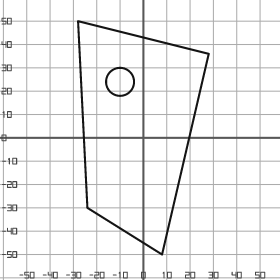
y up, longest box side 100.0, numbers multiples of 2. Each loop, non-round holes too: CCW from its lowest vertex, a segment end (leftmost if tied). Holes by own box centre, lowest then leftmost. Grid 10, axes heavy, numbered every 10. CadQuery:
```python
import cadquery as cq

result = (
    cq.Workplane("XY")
    .moveTo(8.0, -50.0)
    .lineTo(28.0, 36.0)
    .lineTo(-28.0, 50.0)
    .lineTo(-24.0, -30.0)
    .close()
    .moveTo(-10.0, 24.0)
    .circle(6.0)
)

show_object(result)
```